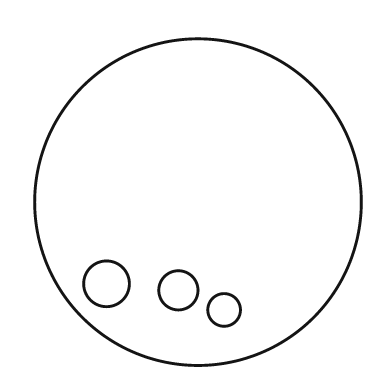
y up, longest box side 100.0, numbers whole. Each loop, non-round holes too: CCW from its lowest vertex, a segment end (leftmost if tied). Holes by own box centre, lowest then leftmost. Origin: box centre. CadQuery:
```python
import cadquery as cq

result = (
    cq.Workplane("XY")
    .moveTo(0.0, 0.0)
    .circle(50.0)
    .moveTo(8.0, -33.0)
    .circle(5.0)
    .moveTo(-6.0, -27.0)
    .circle(6.0)
    .moveTo(-28.0, -25.0)
    .circle(7.0)
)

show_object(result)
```